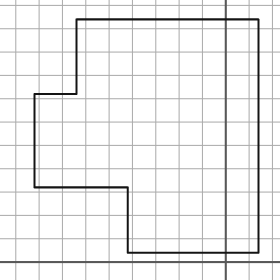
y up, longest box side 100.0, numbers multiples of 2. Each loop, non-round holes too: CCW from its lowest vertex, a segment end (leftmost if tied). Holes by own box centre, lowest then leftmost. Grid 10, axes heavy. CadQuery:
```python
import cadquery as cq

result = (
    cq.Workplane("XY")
    .moveTo(-42.0, 4.0)
    .lineTo(14.0, 4.0)
    .lineTo(14.0, 104.0)
    .lineTo(-64.0, 104.0)
    .lineTo(-64.0, 72.0)
    .lineTo(-82.0, 72.0)
    .lineTo(-82.0, 32.0)
    .lineTo(-42.0, 32.0)
    .close()
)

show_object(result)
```